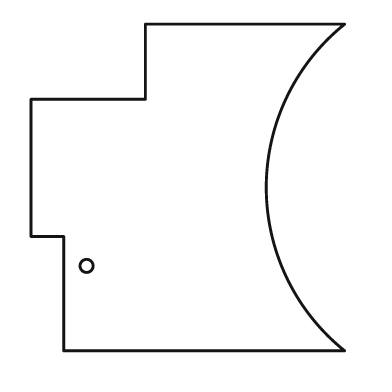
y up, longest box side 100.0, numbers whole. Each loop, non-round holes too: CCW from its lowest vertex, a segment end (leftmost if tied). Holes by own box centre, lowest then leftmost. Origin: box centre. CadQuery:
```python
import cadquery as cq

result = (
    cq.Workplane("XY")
    .moveTo(-38.0, -50.0)
    .lineTo(48.0, -50.0)
    .threePointArc((24.0, 0.0), (48.0, 50.0))
    .lineTo(-13.0, 50.0)
    .lineTo(-13.0, 27.0)
    .lineTo(-48.0, 27.0)
    .lineTo(-48.0, -15.0)
    .lineTo(-38.0, -15.0)
    .close()
    .moveTo(-31.0, -24.0)
    .circle(2.0)
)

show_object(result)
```